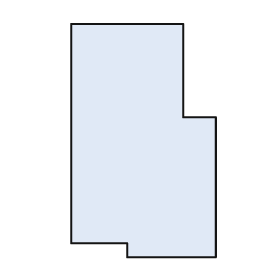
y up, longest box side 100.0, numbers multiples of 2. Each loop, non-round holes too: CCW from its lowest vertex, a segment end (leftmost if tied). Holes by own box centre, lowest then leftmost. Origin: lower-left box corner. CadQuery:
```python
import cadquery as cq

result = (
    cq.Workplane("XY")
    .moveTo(24.0, 0.0)
    .lineTo(62.0, 0.0)
    .lineTo(62.0, 60.0)
    .lineTo(48.0, 60.0)
    .lineTo(48.0, 100.0)
    .lineTo(0.0, 100.0)
    .lineTo(0.0, 6.0)
    .lineTo(24.0, 6.0)
    .close()
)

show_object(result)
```